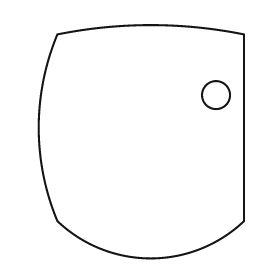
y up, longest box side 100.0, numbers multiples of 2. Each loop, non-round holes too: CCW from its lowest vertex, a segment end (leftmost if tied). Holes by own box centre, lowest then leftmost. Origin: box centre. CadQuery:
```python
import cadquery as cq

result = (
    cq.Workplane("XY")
    .moveTo(-36.0, -34.0)
    .threePointArc((4.0, -50.0), (44.0, -34.0))
    .lineTo(44.0, 46.0)
    .threePointArc((4.0, 50.0), (-36.0, 46.0))
    .threePointArc((-44.0, 6.0), (-36.0, -34.0))
    .close()
    .moveTo(32.0, 20.0)
    .circle(6.0)
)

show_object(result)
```